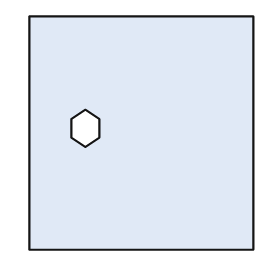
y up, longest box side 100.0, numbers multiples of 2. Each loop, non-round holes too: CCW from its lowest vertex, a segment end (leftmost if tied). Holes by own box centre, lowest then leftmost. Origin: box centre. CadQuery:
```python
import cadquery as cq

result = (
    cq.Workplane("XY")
    .moveTo(-48.0, -50.0)
    .lineTo(48.0, -50.0)
    .lineTo(48.0, 50.0)
    .lineTo(-48.0, 50.0)
    .close()
    .moveTo(-24.0, -6.0)
    .lineTo(-18.0, -2.0)
    .lineTo(-18.0, 6.0)
    .lineTo(-24.0, 10.0)
    .lineTo(-30.0, 6.0)
    .lineTo(-30.0, -2.0)
    .close()
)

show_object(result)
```